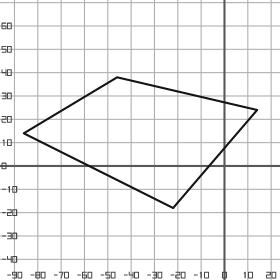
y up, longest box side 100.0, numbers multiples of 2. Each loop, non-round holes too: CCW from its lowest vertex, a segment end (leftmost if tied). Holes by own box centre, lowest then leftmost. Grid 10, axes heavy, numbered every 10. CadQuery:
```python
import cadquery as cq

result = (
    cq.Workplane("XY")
    .moveTo(-22.0, -18.0)
    .lineTo(14.0, 24.0)
    .lineTo(-46.0, 38.0)
    .lineTo(-86.0, 14.0)
    .close()
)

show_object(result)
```